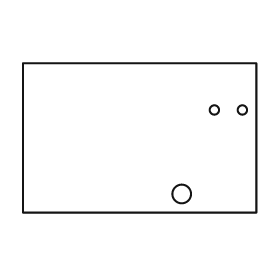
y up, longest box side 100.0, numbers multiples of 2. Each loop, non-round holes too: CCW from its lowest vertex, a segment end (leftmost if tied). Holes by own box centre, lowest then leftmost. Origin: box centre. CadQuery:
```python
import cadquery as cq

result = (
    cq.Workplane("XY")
    .moveTo(-50.0, -32.0)
    .lineTo(50.0, -32.0)
    .lineTo(50.0, 32.0)
    .lineTo(-50.0, 32.0)
    .close()
    .moveTo(18.0, -24.0)
    .circle(4.0)
    .moveTo(32.0, 12.0)
    .circle(2.0)
    .moveTo(44.0, 12.0)
    .circle(2.0)
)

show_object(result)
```